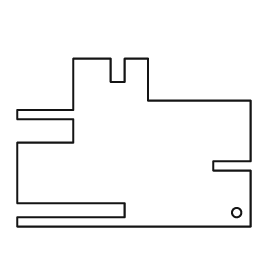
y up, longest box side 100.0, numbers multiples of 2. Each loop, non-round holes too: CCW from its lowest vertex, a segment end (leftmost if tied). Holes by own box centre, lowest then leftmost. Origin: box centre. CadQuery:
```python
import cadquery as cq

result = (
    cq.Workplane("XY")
    .moveTo(-50.0, -36.0)
    .lineTo(50.0, -36.0)
    .lineTo(50.0, -12.0)
    .lineTo(34.0, -12.0)
    .lineTo(34.0, -8.0)
    .lineTo(50.0, -8.0)
    .lineTo(50.0, 18.0)
    .lineTo(6.0, 18.0)
    .lineTo(6.0, 36.0)
    .lineTo(-4.0, 36.0)
    .lineTo(-4.0, 26.0)
    .lineTo(-10.0, 26.0)
    .lineTo(-10.0, 36.0)
    .lineTo(-26.0, 36.0)
    .lineTo(-26.0, 14.0)
    .lineTo(-50.0, 14.0)
    .lineTo(-50.0, 10.0)
    .lineTo(-26.0, 10.0)
    .lineTo(-26.0, 0.0)
    .lineTo(-50.0, 0.0)
    .lineTo(-50.0, -26.0)
    .lineTo(-4.0, -26.0)
    .lineTo(-4.0, -32.0)
    .lineTo(-50.0, -32.0)
    .close()
    .moveTo(44.0, -30.0)
    .circle(2.0)
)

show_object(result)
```